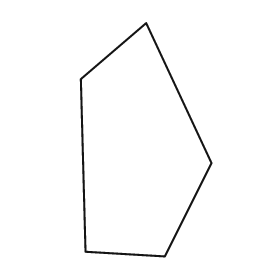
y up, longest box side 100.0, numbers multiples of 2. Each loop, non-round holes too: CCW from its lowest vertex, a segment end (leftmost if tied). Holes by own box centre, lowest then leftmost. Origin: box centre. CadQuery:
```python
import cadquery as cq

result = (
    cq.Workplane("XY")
    .moveTo(8.0, -50.0)
    .lineTo(28.0, -10.0)
    .lineTo(0.0, 50.0)
    .lineTo(-28.0, 26.0)
    .lineTo(-26.0, -48.0)
    .close()
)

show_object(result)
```